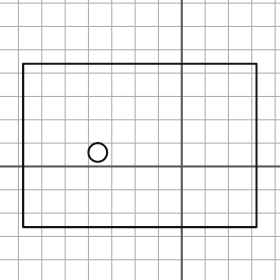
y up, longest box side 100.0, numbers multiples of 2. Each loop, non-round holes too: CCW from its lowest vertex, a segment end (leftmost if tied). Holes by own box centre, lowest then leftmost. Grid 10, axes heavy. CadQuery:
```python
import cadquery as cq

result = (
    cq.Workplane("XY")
    .moveTo(-68.0, -26.0)
    .lineTo(32.0, -26.0)
    .lineTo(32.0, 44.0)
    .lineTo(-68.0, 44.0)
    .close()
    .moveTo(-36.0, 6.0)
    .circle(4.0)
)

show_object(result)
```